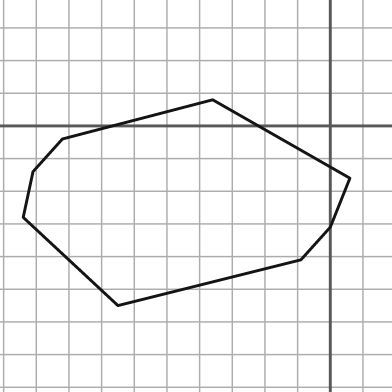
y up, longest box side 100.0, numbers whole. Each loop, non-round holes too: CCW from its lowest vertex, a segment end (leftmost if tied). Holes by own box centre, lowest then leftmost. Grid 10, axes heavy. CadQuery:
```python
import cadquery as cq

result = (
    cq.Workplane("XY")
    .moveTo(-65.0, -55.0)
    .lineTo(-9.0, -41.0)
    .lineTo(0.0, -31.0)
    .lineTo(6.0, -16.0)
    .lineTo(-36.0, 8.0)
    .lineTo(-82.0, -4.0)
    .lineTo(-91.0, -14.0)
    .lineTo(-94.0, -28.0)
    .close()
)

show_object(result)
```